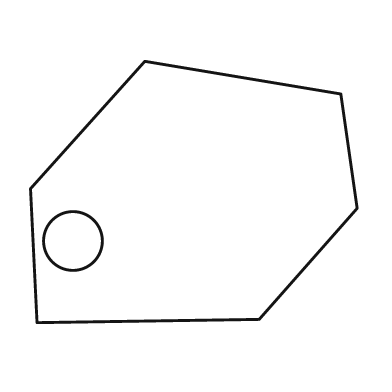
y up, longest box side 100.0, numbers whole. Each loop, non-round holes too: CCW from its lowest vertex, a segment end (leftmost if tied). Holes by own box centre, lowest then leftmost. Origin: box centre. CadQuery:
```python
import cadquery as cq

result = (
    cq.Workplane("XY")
    .moveTo(-48.0, -40.0)
    .lineTo(20.0, -39.0)
    .lineTo(50.0, -5.0)
    .lineTo(45.0, 30.0)
    .lineTo(-15.0, 40.0)
    .lineTo(-50.0, 1.0)
    .close()
    .moveTo(-37.0, -15.0)
    .circle(9.0)
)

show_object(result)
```